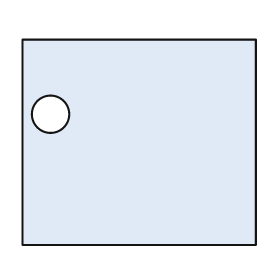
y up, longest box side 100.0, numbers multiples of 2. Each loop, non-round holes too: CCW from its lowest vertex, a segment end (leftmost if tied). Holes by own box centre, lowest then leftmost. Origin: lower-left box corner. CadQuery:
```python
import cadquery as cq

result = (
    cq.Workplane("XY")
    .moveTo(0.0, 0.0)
    .lineTo(100.0, 0.0)
    .lineTo(100.0, 88.0)
    .lineTo(0.0, 88.0)
    .close()
    .moveTo(12.0, 56.0)
    .circle(8.0)
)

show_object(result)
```